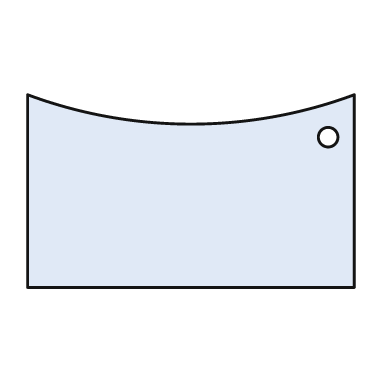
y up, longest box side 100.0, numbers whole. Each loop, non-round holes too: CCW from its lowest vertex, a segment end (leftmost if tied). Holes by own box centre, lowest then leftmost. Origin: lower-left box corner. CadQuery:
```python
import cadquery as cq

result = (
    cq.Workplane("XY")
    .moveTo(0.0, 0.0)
    .lineTo(100.0, 0.0)
    .lineTo(100.0, 59.0)
    .threePointArc((50.0, 50.0), (0.0, 59.0))
    .close()
    .moveTo(92.0, 46.0)
    .circle(3.0)
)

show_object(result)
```